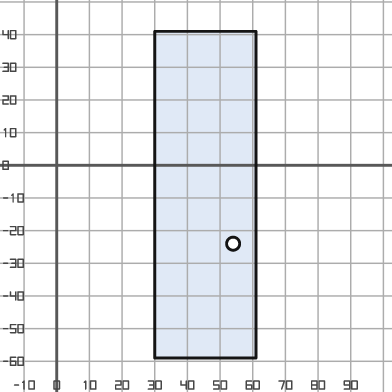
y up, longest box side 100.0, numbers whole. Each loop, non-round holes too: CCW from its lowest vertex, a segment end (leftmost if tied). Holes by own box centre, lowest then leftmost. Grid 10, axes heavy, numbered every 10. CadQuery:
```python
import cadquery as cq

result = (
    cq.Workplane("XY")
    .moveTo(30.0, -59.0)
    .lineTo(61.0, -59.0)
    .lineTo(61.0, 41.0)
    .lineTo(30.0, 41.0)
    .close()
    .moveTo(54.0, -24.0)
    .circle(2.0)
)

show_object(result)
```